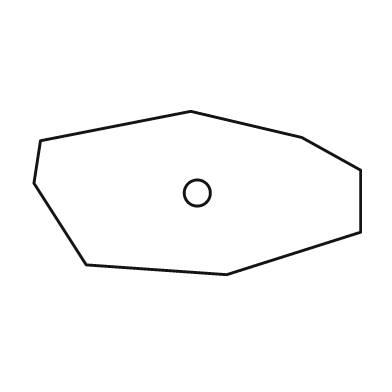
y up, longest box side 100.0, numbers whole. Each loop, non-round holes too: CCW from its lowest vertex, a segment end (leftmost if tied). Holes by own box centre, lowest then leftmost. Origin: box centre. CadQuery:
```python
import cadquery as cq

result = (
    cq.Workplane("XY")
    .moveTo(9.0, -25.0)
    .lineTo(50.0, -12.0)
    .lineTo(50.0, 7.0)
    .lineTo(32.0, 17.0)
    .lineTo(-2.0, 25.0)
    .lineTo(-48.0, 16.0)
    .lineTo(-50.0, 3.0)
    .lineTo(-34.0, -22.0)
    .close()
    .moveTo(0.0, 0.0)
    .circle(4.0)
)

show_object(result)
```